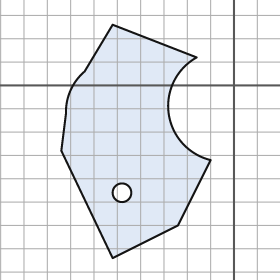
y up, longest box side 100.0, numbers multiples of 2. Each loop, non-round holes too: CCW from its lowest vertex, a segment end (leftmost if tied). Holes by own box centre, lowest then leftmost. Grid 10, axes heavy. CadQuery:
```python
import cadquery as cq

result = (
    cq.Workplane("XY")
    .moveTo(-52.0, -74.0)
    .lineTo(-24.0, -60.0)
    .lineTo(-10.0, -32.0)
    .threePointArc((-28.0, -12.0), (-16.0, 12.0))
    .lineTo(-52.0, 26.0)
    .lineTo(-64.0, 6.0)
    .threePointArc((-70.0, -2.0), (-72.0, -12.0))
    .lineTo(-74.0, -28.0)
    .close()
    .moveTo(-48.0, -46.0)
    .circle(4.0)
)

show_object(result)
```